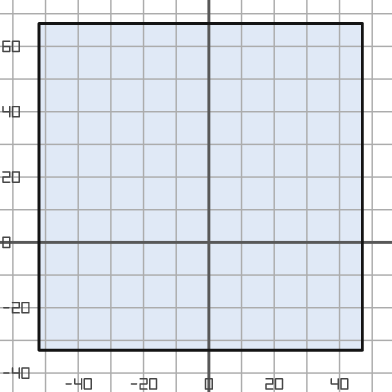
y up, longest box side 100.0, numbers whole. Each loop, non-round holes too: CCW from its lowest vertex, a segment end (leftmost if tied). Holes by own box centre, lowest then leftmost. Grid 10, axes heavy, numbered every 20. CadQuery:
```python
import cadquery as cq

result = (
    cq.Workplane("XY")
    .moveTo(-52.0, -33.0)
    .lineTo(47.0, -33.0)
    .lineTo(47.0, 67.0)
    .lineTo(-52.0, 67.0)
    .close()
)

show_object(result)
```